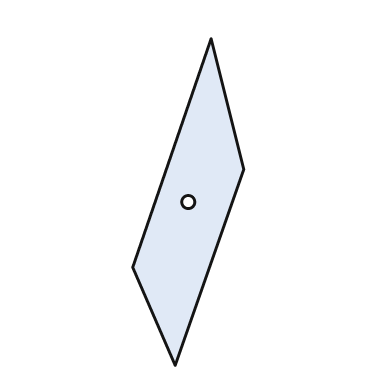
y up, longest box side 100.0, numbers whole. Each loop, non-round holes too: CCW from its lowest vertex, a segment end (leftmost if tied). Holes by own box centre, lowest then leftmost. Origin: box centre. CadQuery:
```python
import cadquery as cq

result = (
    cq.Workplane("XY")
    .moveTo(-4.0, -50.0)
    .lineTo(17.0, 10.0)
    .lineTo(7.0, 50.0)
    .lineTo(-17.0, -20.0)
    .close()
    .moveTo(0.0, 0.0)
    .circle(2.0)
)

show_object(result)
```